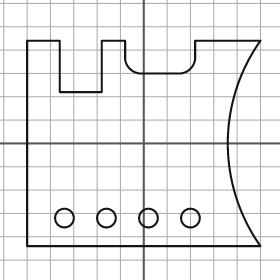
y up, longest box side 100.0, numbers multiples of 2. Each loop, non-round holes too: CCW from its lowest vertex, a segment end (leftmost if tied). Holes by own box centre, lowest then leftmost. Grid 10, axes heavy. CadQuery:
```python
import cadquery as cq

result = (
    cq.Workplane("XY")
    .moveTo(-50.0, -44.0)
    .lineTo(50.0, -44.0)
    .threePointArc((36.0, 0.0), (50.0, 44.0))
    .lineTo(22.0, 44.0)
    .lineTo(22.0, 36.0)
    .threePointArc((20.0, 32.0), (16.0, 30.0))
    .lineTo(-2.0, 30.0)
    .threePointArc((-6.0, 32.0), (-8.0, 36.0))
    .lineTo(-8.0, 44.0)
    .lineTo(-18.0, 44.0)
    .lineTo(-18.0, 22.0)
    .lineTo(-36.0, 22.0)
    .lineTo(-36.0, 44.0)
    .lineTo(-50.0, 44.0)
    .close()
    .moveTo(-34.0, -32.0)
    .circle(4.0)
    .moveTo(-16.0, -32.0)
    .circle(4.0)
    .moveTo(2.0, -32.0)
    .circle(4.0)
    .moveTo(20.0, -32.0)
    .circle(4.0)
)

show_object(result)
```